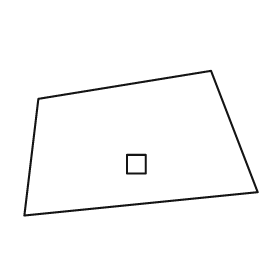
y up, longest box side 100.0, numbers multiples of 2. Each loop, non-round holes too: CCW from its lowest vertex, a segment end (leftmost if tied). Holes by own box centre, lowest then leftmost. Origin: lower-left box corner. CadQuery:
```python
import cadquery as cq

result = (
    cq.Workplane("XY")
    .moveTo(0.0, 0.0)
    .lineTo(100.0, 10.0)
    .lineTo(80.0, 62.0)
    .lineTo(6.0, 50.0)
    .close()
    .moveTo(44.0, 18.0)
    .lineTo(52.0, 18.0)
    .lineTo(52.0, 26.0)
    .lineTo(44.0, 26.0)
    .close()
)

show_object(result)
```